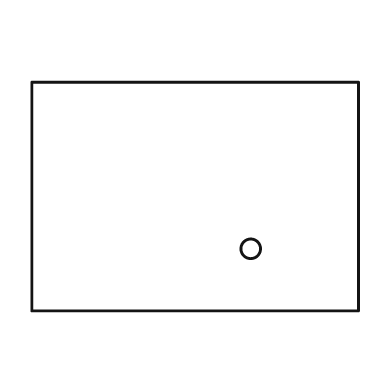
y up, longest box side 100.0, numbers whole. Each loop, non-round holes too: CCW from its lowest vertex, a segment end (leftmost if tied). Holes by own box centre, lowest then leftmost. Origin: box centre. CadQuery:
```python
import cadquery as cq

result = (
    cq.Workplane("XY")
    .moveTo(-50.0, -35.0)
    .lineTo(50.0, -35.0)
    .lineTo(50.0, 35.0)
    .lineTo(-50.0, 35.0)
    .close()
    .moveTo(17.0, -16.0)
    .circle(3.0)
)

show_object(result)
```